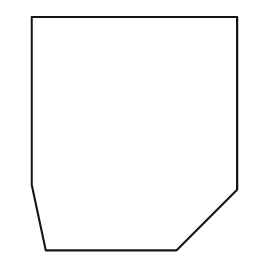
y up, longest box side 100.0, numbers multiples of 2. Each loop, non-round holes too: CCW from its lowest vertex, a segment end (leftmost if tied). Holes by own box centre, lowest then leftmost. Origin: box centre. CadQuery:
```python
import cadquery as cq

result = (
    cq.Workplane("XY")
    .moveTo(-38.0, -50.0)
    .lineTo(18.0, -50.0)
    .lineTo(44.0, -24.0)
    .lineTo(44.0, 50.0)
    .lineTo(-44.0, 50.0)
    .lineTo(-44.0, -22.0)
    .close()
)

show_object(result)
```